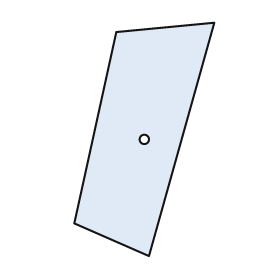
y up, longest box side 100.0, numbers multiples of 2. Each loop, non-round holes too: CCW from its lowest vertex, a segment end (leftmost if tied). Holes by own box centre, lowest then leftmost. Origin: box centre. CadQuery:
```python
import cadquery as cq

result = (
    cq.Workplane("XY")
    .moveTo(2.0, -50.0)
    .lineTo(30.0, 50.0)
    .lineTo(-12.0, 46.0)
    .lineTo(-30.0, -36.0)
    .close()
    .moveTo(0.0, 0.0)
    .circle(2.0)
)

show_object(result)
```